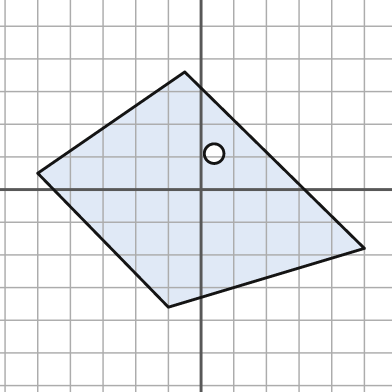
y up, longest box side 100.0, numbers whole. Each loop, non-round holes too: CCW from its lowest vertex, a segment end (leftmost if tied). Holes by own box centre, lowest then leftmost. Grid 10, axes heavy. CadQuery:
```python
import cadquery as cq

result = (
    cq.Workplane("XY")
    .moveTo(-10.0, -36.0)
    .lineTo(50.0, -18.0)
    .lineTo(-5.0, 36.0)
    .lineTo(-50.0, 5.0)
    .close()
    .moveTo(4.0, 11.0)
    .circle(3.0)
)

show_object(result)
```